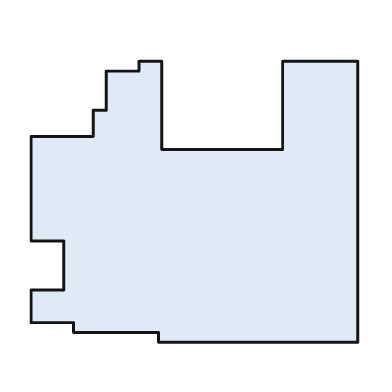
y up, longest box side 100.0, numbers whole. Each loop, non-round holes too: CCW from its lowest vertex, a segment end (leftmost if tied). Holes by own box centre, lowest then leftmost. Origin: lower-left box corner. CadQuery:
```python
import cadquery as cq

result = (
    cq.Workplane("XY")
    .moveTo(39.0, 0.0)
    .lineTo(100.0, 0.0)
    .lineTo(100.0, 86.0)
    .lineTo(77.0, 86.0)
    .lineTo(77.0, 59.0)
    .lineTo(40.0, 59.0)
    .lineTo(40.0, 86.0)
    .lineTo(33.0, 86.0)
    .lineTo(33.0, 83.0)
    .lineTo(23.0, 83.0)
    .lineTo(23.0, 71.0)
    .lineTo(19.0, 71.0)
    .lineTo(19.0, 63.0)
    .lineTo(0.0, 63.0)
    .lineTo(0.0, 31.0)
    .lineTo(10.0, 31.0)
    .lineTo(10.0, 16.0)
    .lineTo(0.0, 16.0)
    .lineTo(0.0, 6.0)
    .lineTo(13.0, 6.0)
    .lineTo(13.0, 3.0)
    .lineTo(39.0, 3.0)
    .close()
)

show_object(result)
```